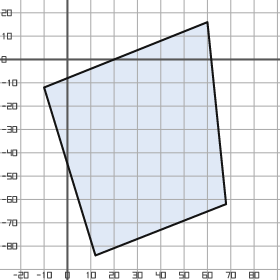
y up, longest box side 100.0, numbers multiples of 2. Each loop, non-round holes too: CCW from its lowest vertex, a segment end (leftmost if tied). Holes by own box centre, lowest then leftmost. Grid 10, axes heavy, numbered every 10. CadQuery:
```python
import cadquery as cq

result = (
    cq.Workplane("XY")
    .moveTo(12.0, -84.0)
    .lineTo(68.0, -62.0)
    .lineTo(60.0, 16.0)
    .lineTo(-10.0, -12.0)
    .close()
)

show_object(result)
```